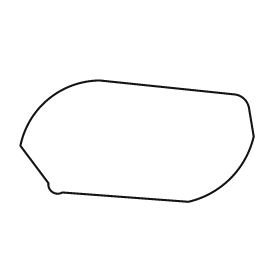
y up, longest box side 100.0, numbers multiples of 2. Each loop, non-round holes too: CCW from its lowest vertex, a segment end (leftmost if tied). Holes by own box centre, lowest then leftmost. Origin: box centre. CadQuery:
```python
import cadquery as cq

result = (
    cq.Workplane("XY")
    .moveTo(22.0, -26.0)
    .threePointArc((40.0, -16.0), (50.0, 2.0))
    .lineTo(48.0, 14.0)
    .threePointArc((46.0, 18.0), (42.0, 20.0))
    .lineTo(-16.0, 26.0)
    .threePointArc((-38.0, 18.0), (-50.0, -2.0))
    .lineTo(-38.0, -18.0)
    .threePointArc((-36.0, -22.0), (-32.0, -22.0))
    .close()
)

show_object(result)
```